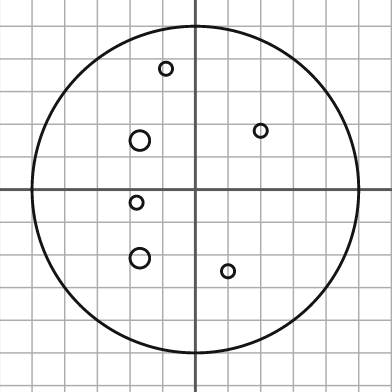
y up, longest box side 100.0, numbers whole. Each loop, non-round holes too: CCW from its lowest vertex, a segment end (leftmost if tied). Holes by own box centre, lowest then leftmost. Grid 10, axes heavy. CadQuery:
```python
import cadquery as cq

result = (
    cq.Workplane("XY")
    .moveTo(0.0, 0.0)
    .circle(50.0)
    .moveTo(10.0, -25.0)
    .circle(2.0)
    .moveTo(-17.0, -21.0)
    .circle(3.0)
    .moveTo(-18.0, -4.0)
    .circle(2.0)
    .moveTo(-17.0, 15.0)
    .circle(3.0)
    .moveTo(20.0, 18.0)
    .circle(2.0)
    .moveTo(-9.0, 37.0)
    .circle(2.0)
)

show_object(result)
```